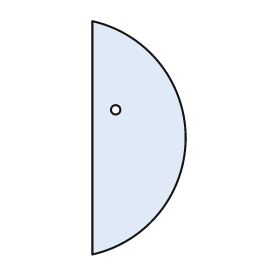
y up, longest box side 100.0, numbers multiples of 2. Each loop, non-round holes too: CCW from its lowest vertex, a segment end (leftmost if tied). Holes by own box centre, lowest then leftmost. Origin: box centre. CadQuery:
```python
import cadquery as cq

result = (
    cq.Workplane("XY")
    .moveTo(-20.0, -50.0)
    .threePointArc((20.0, 0.0), (-20.0, 50.0))
    .close()
    .moveTo(-10.0, 12.0)
    .circle(2.0)
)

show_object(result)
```